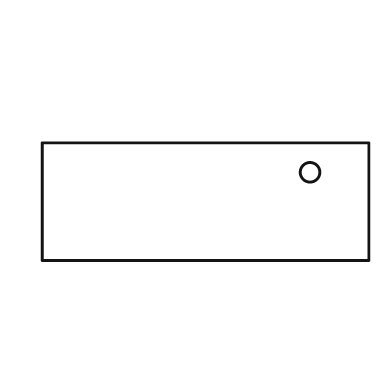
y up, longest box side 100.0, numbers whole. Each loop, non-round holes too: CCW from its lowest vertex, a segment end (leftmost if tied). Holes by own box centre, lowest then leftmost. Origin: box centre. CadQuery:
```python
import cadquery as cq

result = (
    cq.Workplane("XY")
    .moveTo(-50.0, -18.0)
    .lineTo(50.0, -18.0)
    .lineTo(50.0, 18.0)
    .lineTo(-50.0, 18.0)
    .close()
    .moveTo(32.0, 9.0)
    .circle(3.0)
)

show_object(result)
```